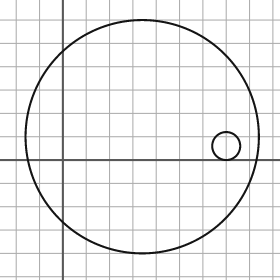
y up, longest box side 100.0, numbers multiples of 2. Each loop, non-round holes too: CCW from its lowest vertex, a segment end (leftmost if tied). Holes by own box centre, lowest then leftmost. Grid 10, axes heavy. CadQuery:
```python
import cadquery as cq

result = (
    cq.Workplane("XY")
    .moveTo(34.0, 10.0)
    .circle(50.0)
    .moveTo(70.0, 6.0)
    .circle(6.0)
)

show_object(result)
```